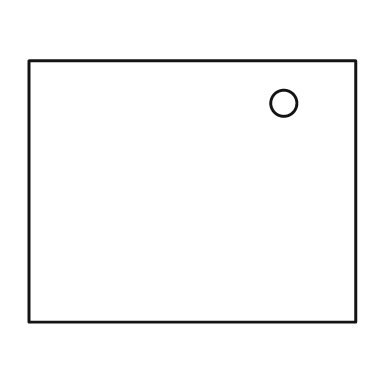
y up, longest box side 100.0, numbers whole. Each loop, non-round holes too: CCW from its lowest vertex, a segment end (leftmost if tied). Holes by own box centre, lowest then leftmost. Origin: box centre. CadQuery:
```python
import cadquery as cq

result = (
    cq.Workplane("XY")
    .moveTo(-50.0, -40.0)
    .lineTo(50.0, -40.0)
    .lineTo(50.0, 40.0)
    .lineTo(-50.0, 40.0)
    .close()
    .moveTo(28.0, 27.0)
    .circle(4.0)
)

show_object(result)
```